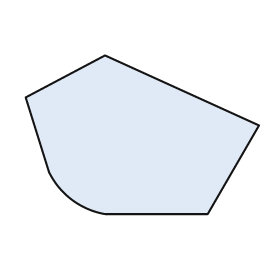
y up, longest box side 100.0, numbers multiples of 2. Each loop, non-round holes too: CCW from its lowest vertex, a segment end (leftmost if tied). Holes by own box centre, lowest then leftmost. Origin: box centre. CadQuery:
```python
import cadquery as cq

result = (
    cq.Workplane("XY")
    .moveTo(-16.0, -34.0)
    .lineTo(28.0, -34.0)
    .lineTo(50.0, 4.0)
    .lineTo(-16.0, 34.0)
    .lineTo(-50.0, 16.0)
    .lineTo(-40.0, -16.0)
    .threePointArc((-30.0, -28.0), (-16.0, -34.0))
    .close()
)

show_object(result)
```